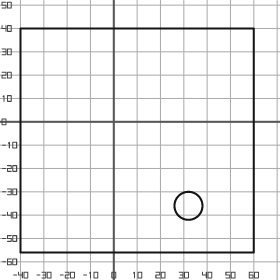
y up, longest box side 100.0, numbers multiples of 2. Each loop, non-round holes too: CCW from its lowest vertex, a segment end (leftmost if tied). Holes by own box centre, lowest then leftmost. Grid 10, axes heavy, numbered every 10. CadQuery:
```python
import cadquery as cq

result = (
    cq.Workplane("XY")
    .moveTo(-40.0, -56.0)
    .lineTo(60.0, -56.0)
    .lineTo(60.0, 40.0)
    .lineTo(-40.0, 40.0)
    .close()
    .moveTo(32.0, -36.0)
    .circle(6.0)
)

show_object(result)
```